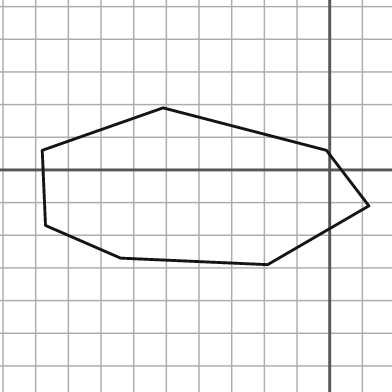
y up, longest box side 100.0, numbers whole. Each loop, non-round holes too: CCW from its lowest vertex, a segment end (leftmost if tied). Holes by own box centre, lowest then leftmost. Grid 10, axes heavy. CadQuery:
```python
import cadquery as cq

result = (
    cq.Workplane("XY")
    .moveTo(-19.0, -29.0)
    .lineTo(12.0, -11.0)
    .lineTo(-1.0, 6.0)
    .lineTo(-51.0, 19.0)
    .lineTo(-88.0, 6.0)
    .lineTo(-87.0, -17.0)
    .lineTo(-64.0, -27.0)
    .close()
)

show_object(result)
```